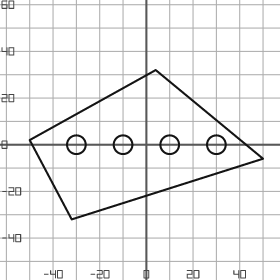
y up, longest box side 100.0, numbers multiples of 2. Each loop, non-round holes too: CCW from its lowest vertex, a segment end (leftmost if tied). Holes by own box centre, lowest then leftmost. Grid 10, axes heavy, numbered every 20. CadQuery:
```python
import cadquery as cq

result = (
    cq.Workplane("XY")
    .moveTo(-32.0, -32.0)
    .lineTo(50.0, -6.0)
    .lineTo(4.0, 32.0)
    .lineTo(-50.0, 2.0)
    .close()
    .moveTo(-30.0, 0.0)
    .circle(4.0)
    .moveTo(-10.0, 0.0)
    .circle(4.0)
    .moveTo(10.0, 0.0)
    .circle(4.0)
    .moveTo(30.0, 0.0)
    .circle(4.0)
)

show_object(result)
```